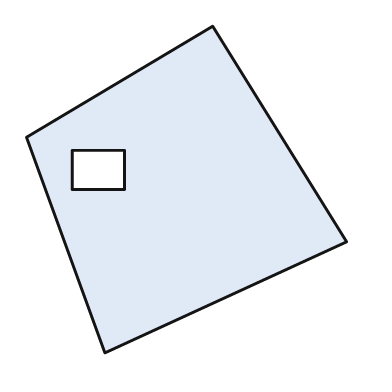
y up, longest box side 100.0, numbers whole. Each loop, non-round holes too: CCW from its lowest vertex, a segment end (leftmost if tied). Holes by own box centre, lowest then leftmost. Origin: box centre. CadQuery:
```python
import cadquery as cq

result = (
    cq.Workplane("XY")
    .moveTo(-25.0, -50.0)
    .lineTo(49.0, -16.0)
    .lineTo(8.0, 50.0)
    .lineTo(-49.0, 16.0)
    .close()
    .moveTo(-35.0, 0.0)
    .lineTo(-19.0, 0.0)
    .lineTo(-19.0, 12.0)
    .lineTo(-35.0, 12.0)
    .close()
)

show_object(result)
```